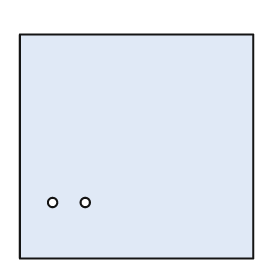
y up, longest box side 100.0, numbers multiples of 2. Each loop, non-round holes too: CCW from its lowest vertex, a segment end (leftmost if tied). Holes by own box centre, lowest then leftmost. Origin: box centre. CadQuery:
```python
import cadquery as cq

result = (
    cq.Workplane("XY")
    .moveTo(-50.0, -48.0)
    .lineTo(50.0, -48.0)
    .lineTo(50.0, 48.0)
    .lineTo(-50.0, 48.0)
    .close()
    .moveTo(-36.0, -24.0)
    .circle(2.0)
    .moveTo(-22.0, -24.0)
    .circle(2.0)
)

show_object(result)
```